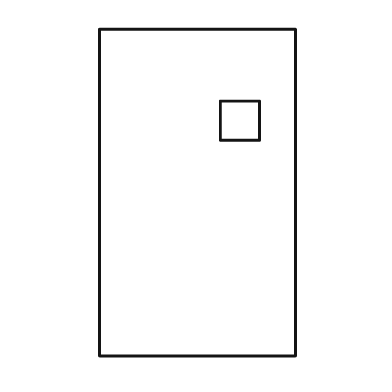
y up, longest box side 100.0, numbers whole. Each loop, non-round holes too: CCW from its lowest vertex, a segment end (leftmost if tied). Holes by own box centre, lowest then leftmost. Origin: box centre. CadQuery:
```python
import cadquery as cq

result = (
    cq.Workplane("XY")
    .moveTo(-30.0, -50.0)
    .lineTo(30.0, -50.0)
    .lineTo(30.0, 50.0)
    .lineTo(-30.0, 50.0)
    .close()
    .moveTo(7.0, 16.0)
    .lineTo(19.0, 16.0)
    .lineTo(19.0, 28.0)
    .lineTo(7.0, 28.0)
    .close()
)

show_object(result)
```